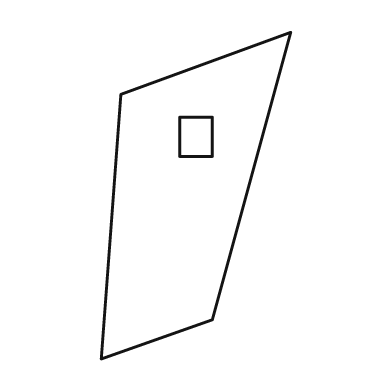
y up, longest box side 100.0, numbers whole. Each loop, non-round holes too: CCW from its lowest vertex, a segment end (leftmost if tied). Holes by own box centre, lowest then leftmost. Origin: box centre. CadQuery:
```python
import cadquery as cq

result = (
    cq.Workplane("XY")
    .moveTo(-29.0, -50.0)
    .lineTo(5.0, -38.0)
    .lineTo(29.0, 50.0)
    .lineTo(-23.0, 31.0)
    .close()
    .moveTo(-5.0, 12.0)
    .lineTo(5.0, 12.0)
    .lineTo(5.0, 24.0)
    .lineTo(-5.0, 24.0)
    .close()
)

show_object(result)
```